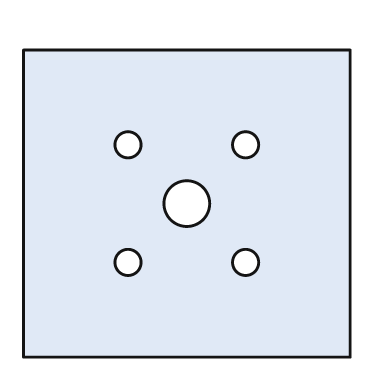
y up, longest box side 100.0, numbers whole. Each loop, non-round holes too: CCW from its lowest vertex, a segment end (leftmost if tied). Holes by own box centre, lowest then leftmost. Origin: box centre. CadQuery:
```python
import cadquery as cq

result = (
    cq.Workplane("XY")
    .moveTo(-50.0, -47.0)
    .lineTo(50.0, -47.0)
    .lineTo(50.0, 47.0)
    .lineTo(-50.0, 47.0)
    .close()
    .moveTo(-18.0, -18.0)
    .circle(4.0)
    .moveTo(18.0, -18.0)
    .circle(4.0)
    .moveTo(0.0, 0.0)
    .circle(7.0)
    .moveTo(-18.0, 18.0)
    .circle(4.0)
    .moveTo(18.0, 18.0)
    .circle(4.0)
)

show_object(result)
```